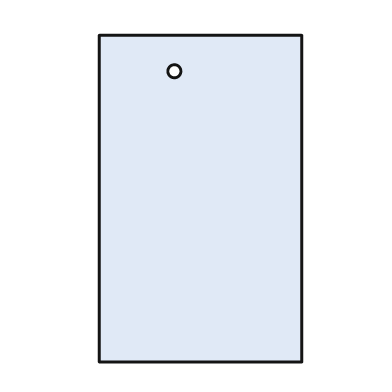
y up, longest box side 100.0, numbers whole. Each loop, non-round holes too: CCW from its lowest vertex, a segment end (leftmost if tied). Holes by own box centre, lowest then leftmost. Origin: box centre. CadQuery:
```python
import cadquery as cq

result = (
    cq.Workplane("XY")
    .moveTo(-31.0, -50.0)
    .lineTo(31.0, -50.0)
    .lineTo(31.0, 50.0)
    .lineTo(-31.0, 50.0)
    .close()
    .moveTo(-8.0, 39.0)
    .circle(2.0)
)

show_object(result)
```